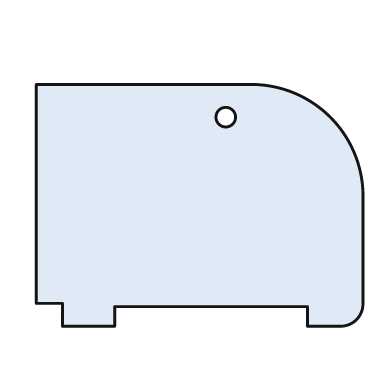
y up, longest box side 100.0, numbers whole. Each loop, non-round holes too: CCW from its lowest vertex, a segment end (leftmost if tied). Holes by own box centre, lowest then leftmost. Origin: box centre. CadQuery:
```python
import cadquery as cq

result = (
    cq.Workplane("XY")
    .moveTo(-42.0, -37.0)
    .lineTo(-26.0, -37.0)
    .lineTo(-26.0, -31.0)
    .lineTo(33.0, -31.0)
    .lineTo(33.0, -37.0)
    .lineTo(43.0, -37.0)
    .threePointArc((48.0, -35.0), (50.0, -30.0))
    .lineTo(50.0, 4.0)
    .threePointArc((40.0, 27.0), (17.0, 37.0))
    .lineTo(-50.0, 37.0)
    .lineTo(-50.0, -30.0)
    .lineTo(-42.0, -30.0)
    .close()
    .moveTo(8.0, 27.0)
    .circle(3.0)
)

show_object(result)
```